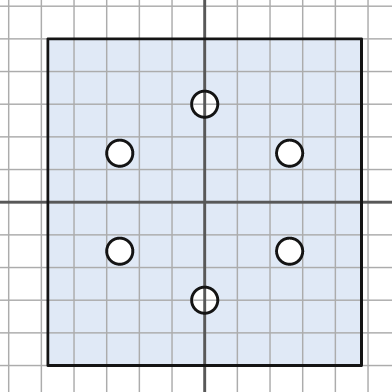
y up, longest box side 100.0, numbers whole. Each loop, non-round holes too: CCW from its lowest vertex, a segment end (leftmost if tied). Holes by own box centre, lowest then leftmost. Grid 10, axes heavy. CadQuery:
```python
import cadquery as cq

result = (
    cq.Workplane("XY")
    .moveTo(-48.0, -50.0)
    .lineTo(48.0, -50.0)
    .lineTo(48.0, 50.0)
    .lineTo(-48.0, 50.0)
    .close()
    .moveTo(0.0, -30.0)
    .circle(4.0)
    .moveTo(-26.0, -15.0)
    .circle(4.0)
    .moveTo(26.0, -15.0)
    .circle(4.0)
    .moveTo(-26.0, 15.0)
    .circle(4.0)
    .moveTo(26.0, 15.0)
    .circle(4.0)
    .moveTo(0.0, 30.0)
    .circle(4.0)
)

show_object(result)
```